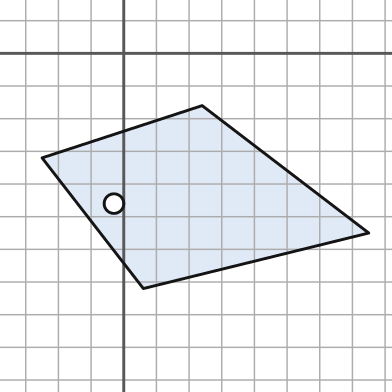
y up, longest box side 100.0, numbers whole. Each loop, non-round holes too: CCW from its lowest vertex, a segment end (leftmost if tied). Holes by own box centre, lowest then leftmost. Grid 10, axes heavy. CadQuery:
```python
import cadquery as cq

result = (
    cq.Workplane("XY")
    .moveTo(6.0, -72.0)
    .lineTo(75.0, -55.0)
    .lineTo(24.0, -16.0)
    .lineTo(-25.0, -32.0)
    .close()
    .moveTo(-3.0, -46.0)
    .circle(3.0)
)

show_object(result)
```